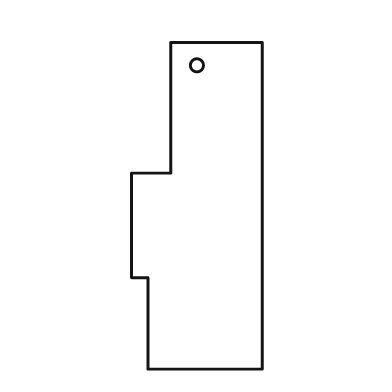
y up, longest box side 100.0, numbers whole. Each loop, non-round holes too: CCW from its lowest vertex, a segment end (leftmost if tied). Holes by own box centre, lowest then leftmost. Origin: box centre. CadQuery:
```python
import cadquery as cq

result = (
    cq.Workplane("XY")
    .moveTo(-15.0, -50.0)
    .lineTo(20.0, -50.0)
    .lineTo(20.0, 50.0)
    .lineTo(-8.0, 50.0)
    .lineTo(-8.0, 10.0)
    .lineTo(-20.0, 10.0)
    .lineTo(-20.0, -22.0)
    .lineTo(-15.0, -22.0)
    .close()
    .moveTo(0.0, 43.0)
    .circle(2.0)
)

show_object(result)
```